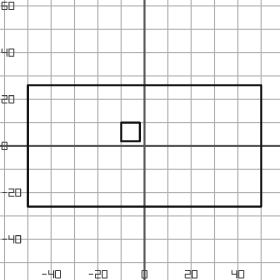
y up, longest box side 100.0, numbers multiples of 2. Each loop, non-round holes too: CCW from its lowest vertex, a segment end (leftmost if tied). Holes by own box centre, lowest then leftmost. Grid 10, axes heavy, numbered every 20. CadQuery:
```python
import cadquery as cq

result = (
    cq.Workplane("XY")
    .moveTo(-50.0, -26.0)
    .lineTo(50.0, -26.0)
    .lineTo(50.0, 26.0)
    .lineTo(-50.0, 26.0)
    .close()
    .moveTo(-10.0, 2.0)
    .lineTo(-2.0, 2.0)
    .lineTo(-2.0, 10.0)
    .lineTo(-10.0, 10.0)
    .close()
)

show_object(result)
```